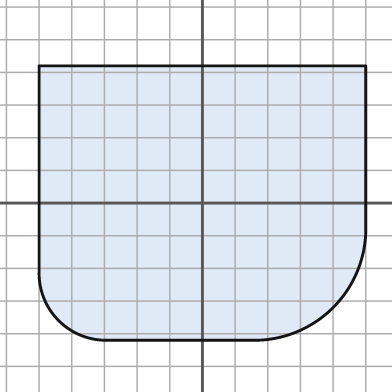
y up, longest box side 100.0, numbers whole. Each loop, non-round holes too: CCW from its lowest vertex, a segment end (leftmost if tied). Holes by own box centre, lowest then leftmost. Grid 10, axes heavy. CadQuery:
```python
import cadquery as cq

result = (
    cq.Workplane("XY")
    .moveTo(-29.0, -42.0)
    .lineTo(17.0, -42.0)
    .threePointArc((40.0, -32.0), (50.0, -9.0))
    .lineTo(50.0, 42.0)
    .lineTo(-50.0, 42.0)
    .lineTo(-50.0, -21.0)
    .threePointArc((-44.0, -36.0), (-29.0, -42.0))
    .close()
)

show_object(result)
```